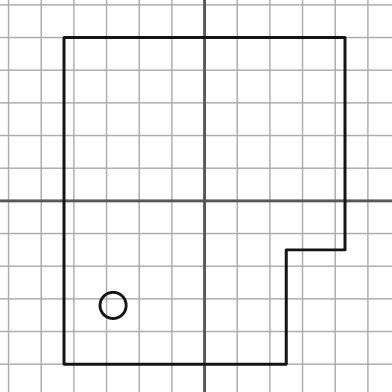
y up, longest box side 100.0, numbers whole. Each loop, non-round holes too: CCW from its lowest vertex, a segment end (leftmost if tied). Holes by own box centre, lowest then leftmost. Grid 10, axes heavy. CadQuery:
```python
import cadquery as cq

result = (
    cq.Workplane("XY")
    .moveTo(-43.0, -50.0)
    .lineTo(25.0, -50.0)
    .lineTo(25.0, -15.0)
    .lineTo(43.0, -15.0)
    .lineTo(43.0, 50.0)
    .lineTo(-43.0, 50.0)
    .close()
    .moveTo(-28.0, -32.0)
    .circle(4.0)
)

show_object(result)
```